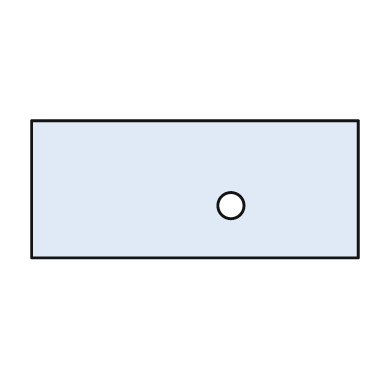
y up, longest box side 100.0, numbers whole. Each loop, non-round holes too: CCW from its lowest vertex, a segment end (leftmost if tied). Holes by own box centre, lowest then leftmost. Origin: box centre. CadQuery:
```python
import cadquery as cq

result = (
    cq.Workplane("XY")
    .moveTo(-50.0, -21.0)
    .lineTo(50.0, -21.0)
    .lineTo(50.0, 21.0)
    .lineTo(-50.0, 21.0)
    .close()
    .moveTo(11.0, -5.0)
    .circle(4.0)
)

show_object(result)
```